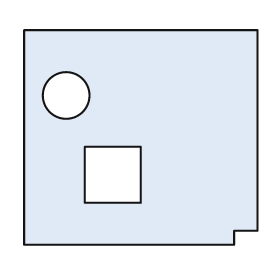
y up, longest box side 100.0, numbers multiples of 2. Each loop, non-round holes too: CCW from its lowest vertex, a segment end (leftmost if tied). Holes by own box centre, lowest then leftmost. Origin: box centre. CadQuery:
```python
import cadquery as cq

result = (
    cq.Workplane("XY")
    .moveTo(-50.0, -46.0)
    .lineTo(40.0, -46.0)
    .lineTo(40.0, -40.0)
    .lineTo(50.0, -40.0)
    .lineTo(50.0, 46.0)
    .lineTo(-50.0, 46.0)
    .close()
    .moveTo(-24.0, -28.0)
    .lineTo(0.0, -28.0)
    .lineTo(0.0, -4.0)
    .lineTo(-24.0, -4.0)
    .close()
    .moveTo(-32.0, 18.0)
    .circle(10.0)
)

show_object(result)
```